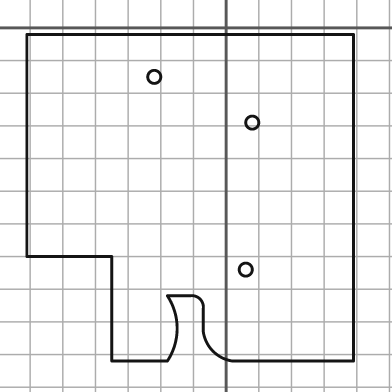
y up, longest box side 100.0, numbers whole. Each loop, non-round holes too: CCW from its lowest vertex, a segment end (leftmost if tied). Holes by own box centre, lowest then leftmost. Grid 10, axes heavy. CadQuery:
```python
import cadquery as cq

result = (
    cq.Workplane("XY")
    .moveTo(-35.0, -102.0)
    .lineTo(-18.0, -102.0)
    .threePointArc((-15.0, -92.0), (-18.0, -82.0))
    .lineTo(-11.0, -82.0)
    .threePointArc((-8.0, -83.0), (-7.0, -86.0))
    .lineTo(-7.0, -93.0)
    .threePointArc((-4.0, -99.0), (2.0, -102.0))
    .lineTo(39.0, -102.0)
    .lineTo(39.0, -2.0)
    .lineTo(-61.0, -2.0)
    .lineTo(-61.0, -70.0)
    .lineTo(-35.0, -70.0)
    .close()
    .moveTo(6.0, -74.0)
    .circle(2.0)
    .moveTo(8.0, -29.0)
    .circle(2.0)
    .moveTo(-22.0, -15.0)
    .circle(2.0)
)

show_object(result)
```